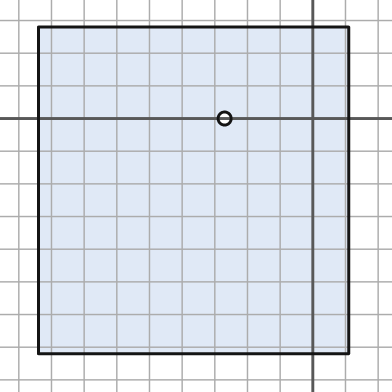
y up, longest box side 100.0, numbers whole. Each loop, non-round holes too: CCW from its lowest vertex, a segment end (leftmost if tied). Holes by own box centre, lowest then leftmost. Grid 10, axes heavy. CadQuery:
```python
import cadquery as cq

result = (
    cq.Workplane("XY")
    .moveTo(-84.0, -72.0)
    .lineTo(11.0, -72.0)
    .lineTo(11.0, 28.0)
    .lineTo(-84.0, 28.0)
    .close()
    .moveTo(-27.0, 0.0)
    .circle(2.0)
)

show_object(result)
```